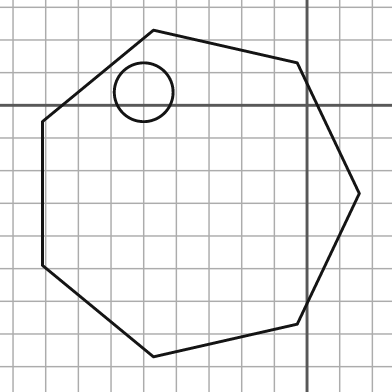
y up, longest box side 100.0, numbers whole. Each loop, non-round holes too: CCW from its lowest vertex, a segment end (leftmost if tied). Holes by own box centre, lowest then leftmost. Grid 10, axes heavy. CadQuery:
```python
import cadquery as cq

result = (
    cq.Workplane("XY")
    .moveTo(-47.0, -77.0)
    .lineTo(-3.0, -67.0)
    .lineTo(16.0, -27.0)
    .lineTo(-3.0, 13.0)
    .lineTo(-47.0, 23.0)
    .lineTo(-81.0, -5.0)
    .lineTo(-81.0, -49.0)
    .close()
    .moveTo(-50.0, 4.0)
    .circle(9.0)
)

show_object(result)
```